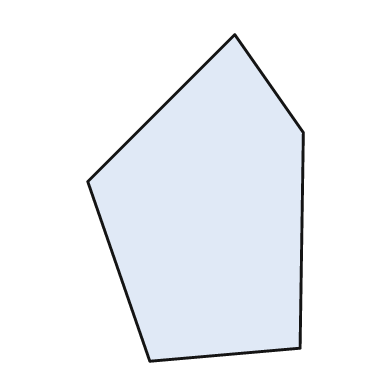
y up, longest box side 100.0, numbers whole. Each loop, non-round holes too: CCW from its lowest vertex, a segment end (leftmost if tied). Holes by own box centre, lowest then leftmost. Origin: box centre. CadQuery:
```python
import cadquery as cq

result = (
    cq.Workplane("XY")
    .moveTo(-14.0, -50.0)
    .lineTo(32.0, -46.0)
    .lineTo(33.0, 20.0)
    .lineTo(12.0, 50.0)
    .lineTo(-33.0, 5.0)
    .close()
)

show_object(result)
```